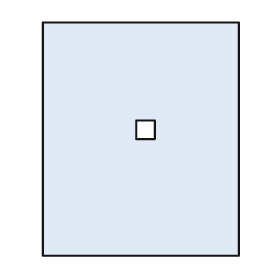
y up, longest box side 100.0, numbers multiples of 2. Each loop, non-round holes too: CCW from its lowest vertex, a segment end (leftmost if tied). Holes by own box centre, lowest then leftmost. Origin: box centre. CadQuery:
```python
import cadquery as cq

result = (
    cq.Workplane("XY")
    .moveTo(-42.0, -50.0)
    .lineTo(42.0, -50.0)
    .lineTo(42.0, 50.0)
    .lineTo(-42.0, 50.0)
    .close()
    .moveTo(-2.0, 0.0)
    .lineTo(6.0, 0.0)
    .lineTo(6.0, 8.0)
    .lineTo(-2.0, 8.0)
    .close()
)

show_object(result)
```